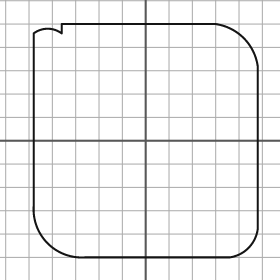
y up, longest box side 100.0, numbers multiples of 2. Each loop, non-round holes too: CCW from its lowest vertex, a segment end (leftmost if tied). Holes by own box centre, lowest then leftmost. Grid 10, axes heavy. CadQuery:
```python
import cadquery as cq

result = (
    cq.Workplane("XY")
    .moveTo(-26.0, -50.0)
    .lineTo(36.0, -50.0)
    .threePointArc((44.0, -46.0), (48.0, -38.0))
    .lineTo(48.0, 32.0)
    .threePointArc((42.0, 44.0), (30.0, 50.0))
    .lineTo(-36.0, 50.0)
    .lineTo(-36.0, 46.0)
    .threePointArc((-42.0, 48.0), (-48.0, 46.0))
    .lineTo(-48.0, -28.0)
    .threePointArc((-42.0, -44.0), (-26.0, -50.0))
    .close()
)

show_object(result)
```